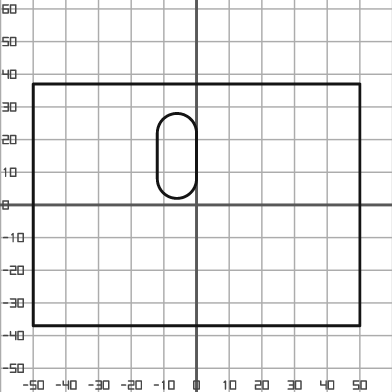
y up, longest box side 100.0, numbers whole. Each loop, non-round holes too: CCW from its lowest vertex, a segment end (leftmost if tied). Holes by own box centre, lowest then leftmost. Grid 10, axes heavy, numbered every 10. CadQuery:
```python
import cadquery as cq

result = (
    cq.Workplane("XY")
    .moveTo(-50.0, -37.0)
    .lineTo(50.0, -37.0)
    .lineTo(50.0, 37.0)
    .lineTo(-50.0, 37.0)
    .close()
    .moveTo(-12.0, 8.0)
    .threePointArc((-6.0, 2.0), (0.0, 8.0))
    .lineTo(0.0, 22.0)
    .threePointArc((-6.0, 28.0), (-12.0, 22.0))
    .close()
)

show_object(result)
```